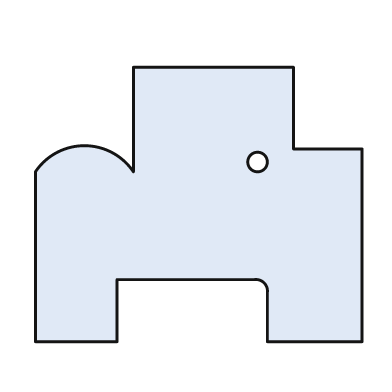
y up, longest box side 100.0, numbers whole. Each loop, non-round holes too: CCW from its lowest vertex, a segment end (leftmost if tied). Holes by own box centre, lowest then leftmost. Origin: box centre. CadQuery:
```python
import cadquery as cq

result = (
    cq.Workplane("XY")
    .moveTo(-50.0, -42.0)
    .lineTo(-25.0, -42.0)
    .lineTo(-25.0, -23.0)
    .lineTo(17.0, -23.0)
    .threePointArc((20.0, -24.0), (21.0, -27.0))
    .lineTo(21.0, -42.0)
    .lineTo(50.0, -42.0)
    .lineTo(50.0, 17.0)
    .lineTo(29.0, 17.0)
    .lineTo(29.0, 42.0)
    .lineTo(-20.0, 42.0)
    .lineTo(-20.0, 10.0)
    .threePointArc((-35.0, 18.0), (-50.0, 10.0))
    .close()
    .moveTo(18.0, 13.0)
    .circle(3.0)
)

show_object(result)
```